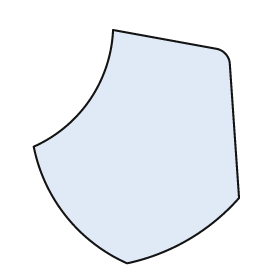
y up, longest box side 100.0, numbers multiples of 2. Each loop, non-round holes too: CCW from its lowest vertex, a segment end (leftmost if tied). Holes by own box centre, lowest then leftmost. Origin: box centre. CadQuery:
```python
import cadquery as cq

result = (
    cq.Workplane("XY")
    .moveTo(-4.0, -50.0)
    .threePointArc((22.0, -40.0), (44.0, -22.0))
    .lineTo(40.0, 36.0)
    .threePointArc((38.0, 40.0), (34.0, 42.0))
    .lineTo(-10.0, 50.0)
    .threePointArc((-20.0, 20.0), (-44.0, 0.0))
    .threePointArc((-30.0, -30.0), (-4.0, -50.0))
    .close()
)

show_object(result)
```